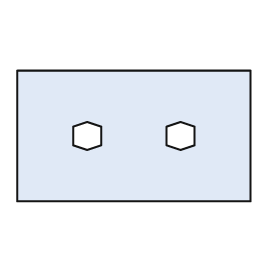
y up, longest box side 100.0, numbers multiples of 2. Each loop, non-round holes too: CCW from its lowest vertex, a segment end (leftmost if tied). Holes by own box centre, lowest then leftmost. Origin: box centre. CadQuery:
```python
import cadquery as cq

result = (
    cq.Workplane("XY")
    .moveTo(-50.0, -28.0)
    .lineTo(50.0, -28.0)
    .lineTo(50.0, 28.0)
    .lineTo(-50.0, 28.0)
    .close()
    .moveTo(-20.0, -6.0)
    .lineTo(-14.0, -4.0)
    .lineTo(-14.0, 4.0)
    .lineTo(-20.0, 6.0)
    .lineTo(-26.0, 4.0)
    .lineTo(-26.0, -4.0)
    .close()
    .moveTo(20.0, -6.0)
    .lineTo(26.0, -4.0)
    .lineTo(26.0, 4.0)
    .lineTo(20.0, 6.0)
    .lineTo(14.0, 4.0)
    .lineTo(14.0, -4.0)
    .close()
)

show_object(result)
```